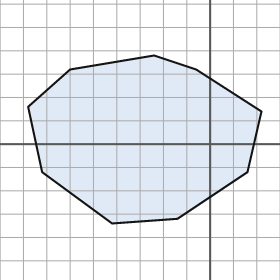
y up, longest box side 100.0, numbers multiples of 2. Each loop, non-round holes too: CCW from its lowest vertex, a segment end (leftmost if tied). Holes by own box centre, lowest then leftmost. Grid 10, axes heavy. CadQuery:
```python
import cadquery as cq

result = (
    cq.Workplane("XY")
    .moveTo(-42.0, -34.0)
    .lineTo(-14.0, -32.0)
    .lineTo(16.0, -12.0)
    .lineTo(22.0, 14.0)
    .lineTo(-6.0, 32.0)
    .lineTo(-24.0, 38.0)
    .lineTo(-60.0, 32.0)
    .lineTo(-78.0, 16.0)
    .lineTo(-72.0, -12.0)
    .close()
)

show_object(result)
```